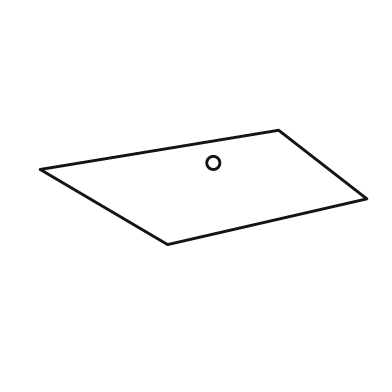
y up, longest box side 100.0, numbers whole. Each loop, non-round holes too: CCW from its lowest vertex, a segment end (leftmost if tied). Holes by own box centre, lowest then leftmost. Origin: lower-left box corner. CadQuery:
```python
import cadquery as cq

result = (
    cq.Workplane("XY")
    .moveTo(39.0, 0.0)
    .lineTo(100.0, 14.0)
    .lineTo(73.0, 35.0)
    .lineTo(0.0, 23.0)
    .close()
    .moveTo(53.0, 25.0)
    .circle(2.0)
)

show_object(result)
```